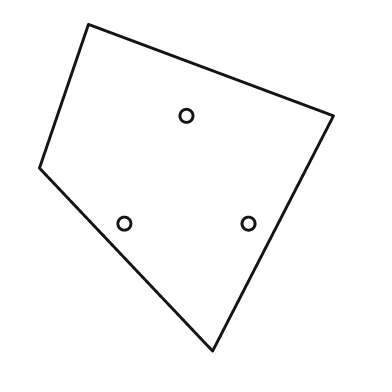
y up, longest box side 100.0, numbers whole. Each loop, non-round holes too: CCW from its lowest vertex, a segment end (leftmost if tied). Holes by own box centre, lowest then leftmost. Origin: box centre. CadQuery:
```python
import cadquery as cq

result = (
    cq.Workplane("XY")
    .moveTo(8.0, -50.0)
    .lineTo(45.0, 22.0)
    .lineTo(-30.0, 50.0)
    .lineTo(-45.0, 6.0)
    .close()
    .moveTo(-19.0, -11.0)
    .circle(2.0)
    .moveTo(19.0, -11.0)
    .circle(2.0)
    .moveTo(0.0, 22.0)
    .circle(2.0)
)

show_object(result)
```